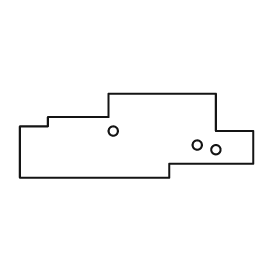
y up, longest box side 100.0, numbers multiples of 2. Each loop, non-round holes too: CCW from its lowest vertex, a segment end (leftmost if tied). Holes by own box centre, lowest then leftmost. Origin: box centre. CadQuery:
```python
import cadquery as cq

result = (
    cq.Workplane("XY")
    .moveTo(-50.0, -18.0)
    .lineTo(14.0, -18.0)
    .lineTo(14.0, -12.0)
    .lineTo(50.0, -12.0)
    .lineTo(50.0, 2.0)
    .lineTo(34.0, 2.0)
    .lineTo(34.0, 18.0)
    .lineTo(-12.0, 18.0)
    .lineTo(-12.0, 8.0)
    .lineTo(-38.0, 8.0)
    .lineTo(-38.0, 4.0)
    .lineTo(-50.0, 4.0)
    .close()
    .moveTo(34.0, -6.0)
    .circle(2.0)
    .moveTo(26.0, -4.0)
    .circle(2.0)
    .moveTo(-10.0, 2.0)
    .circle(2.0)
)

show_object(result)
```